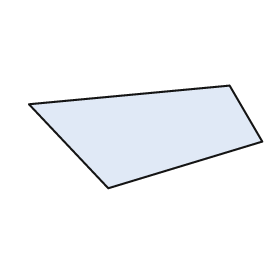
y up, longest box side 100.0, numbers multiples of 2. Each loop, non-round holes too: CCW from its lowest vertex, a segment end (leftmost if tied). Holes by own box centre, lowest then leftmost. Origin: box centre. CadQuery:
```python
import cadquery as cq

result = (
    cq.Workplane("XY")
    .moveTo(-16.0, -22.0)
    .lineTo(50.0, -2.0)
    .lineTo(36.0, 22.0)
    .lineTo(-50.0, 14.0)
    .close()
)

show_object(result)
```